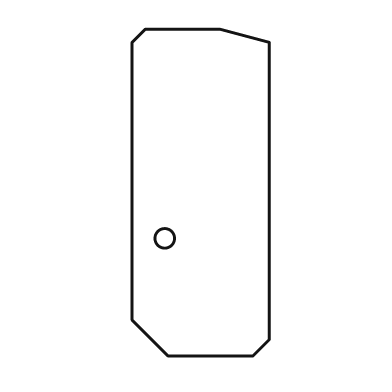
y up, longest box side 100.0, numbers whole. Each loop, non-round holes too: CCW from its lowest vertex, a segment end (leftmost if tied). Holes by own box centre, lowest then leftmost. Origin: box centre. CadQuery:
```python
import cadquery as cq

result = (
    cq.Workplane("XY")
    .moveTo(-10.0, -50.0)
    .lineTo(16.0, -50.0)
    .lineTo(21.0, -45.0)
    .lineTo(21.0, 46.0)
    .lineTo(6.0, 50.0)
    .lineTo(-17.0, 50.0)
    .lineTo(-21.0, 46.0)
    .lineTo(-21.0, -39.0)
    .close()
    .moveTo(-11.0, -14.0)
    .circle(3.0)
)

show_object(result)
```